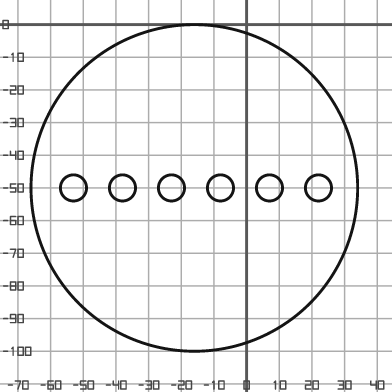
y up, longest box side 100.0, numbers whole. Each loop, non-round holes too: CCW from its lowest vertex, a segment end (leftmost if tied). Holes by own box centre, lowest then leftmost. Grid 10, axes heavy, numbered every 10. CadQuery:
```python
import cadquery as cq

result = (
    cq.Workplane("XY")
    .moveTo(-16.0, -50.0)
    .circle(50.0)
    .moveTo(-53.0, -50.0)
    .circle(4.0)
    .moveTo(-38.0, -50.0)
    .circle(4.0)
    .moveTo(-23.0, -50.0)
    .circle(4.0)
    .moveTo(-8.0, -50.0)
    .circle(4.0)
    .moveTo(7.0, -50.0)
    .circle(4.0)
    .moveTo(22.0, -50.0)
    .circle(4.0)
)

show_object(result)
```